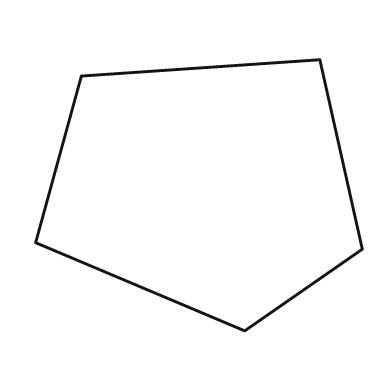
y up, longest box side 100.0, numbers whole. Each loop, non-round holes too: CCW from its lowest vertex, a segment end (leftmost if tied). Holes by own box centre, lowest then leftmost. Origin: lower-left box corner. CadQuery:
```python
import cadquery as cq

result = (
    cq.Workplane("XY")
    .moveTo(64.0, 0.0)
    .lineTo(100.0, 25.0)
    .lineTo(87.0, 83.0)
    .lineTo(14.0, 78.0)
    .lineTo(0.0, 27.0)
    .close()
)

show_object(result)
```